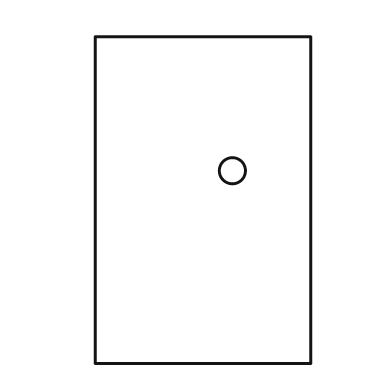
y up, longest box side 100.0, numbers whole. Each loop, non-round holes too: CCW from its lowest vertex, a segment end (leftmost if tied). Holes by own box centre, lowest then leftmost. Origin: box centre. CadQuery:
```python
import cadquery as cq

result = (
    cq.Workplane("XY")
    .moveTo(-33.0, -50.0)
    .lineTo(33.0, -50.0)
    .lineTo(33.0, 50.0)
    .lineTo(-33.0, 50.0)
    .close()
    .moveTo(9.0, 9.0)
    .circle(4.0)
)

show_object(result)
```